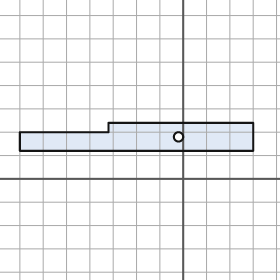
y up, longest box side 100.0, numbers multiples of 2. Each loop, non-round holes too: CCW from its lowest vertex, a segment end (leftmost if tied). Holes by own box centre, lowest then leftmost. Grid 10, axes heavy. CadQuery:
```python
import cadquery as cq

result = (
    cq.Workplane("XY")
    .moveTo(-70.0, 12.0)
    .lineTo(30.0, 12.0)
    .lineTo(30.0, 24.0)
    .lineTo(-32.0, 24.0)
    .lineTo(-32.0, 20.0)
    .lineTo(-70.0, 20.0)
    .close()
    .moveTo(-2.0, 18.0)
    .circle(2.0)
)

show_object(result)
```